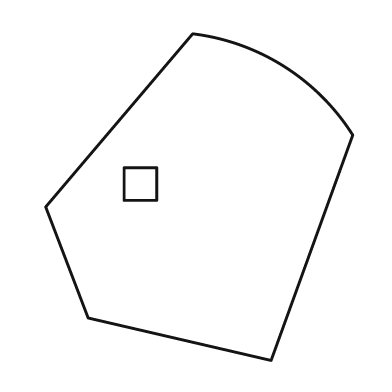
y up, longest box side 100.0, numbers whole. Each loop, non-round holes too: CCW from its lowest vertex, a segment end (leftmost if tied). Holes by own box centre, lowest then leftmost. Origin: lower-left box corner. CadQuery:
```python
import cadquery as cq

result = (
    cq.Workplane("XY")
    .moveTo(69.0, 0.0)
    .lineTo(94.0, 69.0)
    .threePointArc((73.0, 90.0), (45.0, 100.0))
    .lineTo(0.0, 47.0)
    .lineTo(13.0, 13.0)
    .close()
    .moveTo(24.0, 49.0)
    .lineTo(34.0, 49.0)
    .lineTo(34.0, 59.0)
    .lineTo(24.0, 59.0)
    .close()
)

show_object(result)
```